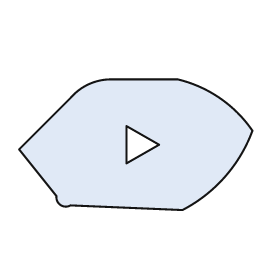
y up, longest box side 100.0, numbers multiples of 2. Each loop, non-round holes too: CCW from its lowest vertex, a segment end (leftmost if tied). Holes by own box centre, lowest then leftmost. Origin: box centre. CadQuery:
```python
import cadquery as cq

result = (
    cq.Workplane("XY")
    .moveTo(20.0, -28.0)
    .threePointArc((38.0, -14.0), (50.0, 6.0))
    .threePointArc((36.0, 20.0), (18.0, 28.0))
    .lineTo(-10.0, 28.0)
    .threePointArc((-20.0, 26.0), (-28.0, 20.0))
    .lineTo(-50.0, -2.0)
    .lineTo(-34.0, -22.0)
    .threePointArc((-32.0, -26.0), (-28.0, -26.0))
    .close()
    .moveTo(-4.0, -8.0)
    .lineTo(10.0, 0.0)
    .lineTo(-4.0, 8.0)
    .close()
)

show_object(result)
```